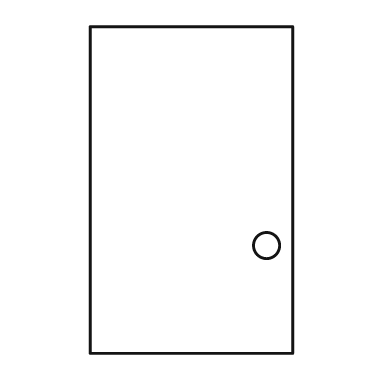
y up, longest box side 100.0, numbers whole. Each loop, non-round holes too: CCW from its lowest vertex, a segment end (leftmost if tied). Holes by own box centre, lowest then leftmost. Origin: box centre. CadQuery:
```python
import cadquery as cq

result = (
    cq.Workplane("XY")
    .moveTo(-31.0, -50.0)
    .lineTo(31.0, -50.0)
    .lineTo(31.0, 50.0)
    .lineTo(-31.0, 50.0)
    .close()
    .moveTo(23.0, -17.0)
    .circle(4.0)
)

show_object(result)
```